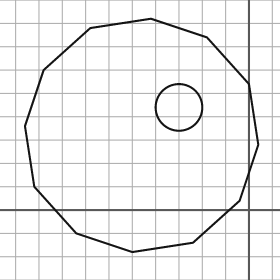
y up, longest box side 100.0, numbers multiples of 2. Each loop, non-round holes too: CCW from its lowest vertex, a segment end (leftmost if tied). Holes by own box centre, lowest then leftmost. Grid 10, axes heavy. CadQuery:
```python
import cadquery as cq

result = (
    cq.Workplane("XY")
    .moveTo(-50.0, -18.0)
    .lineTo(-24.0, -14.0)
    .lineTo(-4.0, 4.0)
    .lineTo(4.0, 28.0)
    .lineTo(0.0, 54.0)
    .lineTo(-18.0, 74.0)
    .lineTo(-42.0, 82.0)
    .lineTo(-68.0, 78.0)
    .lineTo(-88.0, 60.0)
    .lineTo(-96.0, 36.0)
    .lineTo(-92.0, 10.0)
    .lineTo(-74.0, -10.0)
    .close()
    .moveTo(-30.0, 44.0)
    .circle(10.0)
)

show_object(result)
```